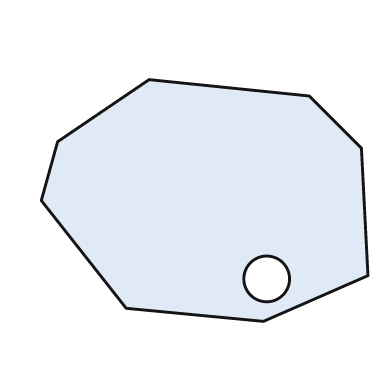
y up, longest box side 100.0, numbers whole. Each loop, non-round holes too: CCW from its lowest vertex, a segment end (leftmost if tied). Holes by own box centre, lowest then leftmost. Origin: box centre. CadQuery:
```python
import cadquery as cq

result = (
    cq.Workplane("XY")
    .moveTo(18.0, -37.0)
    .lineTo(50.0, -23.0)
    .lineTo(48.0, 16.0)
    .lineTo(32.0, 32.0)
    .lineTo(-17.0, 37.0)
    .lineTo(-45.0, 18.0)
    .lineTo(-50.0, 0.0)
    .lineTo(-24.0, -33.0)
    .close()
    .moveTo(19.0, -24.0)
    .circle(7.0)
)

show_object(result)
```